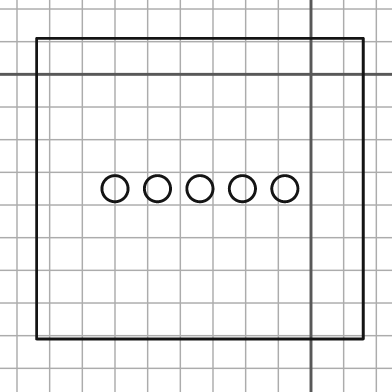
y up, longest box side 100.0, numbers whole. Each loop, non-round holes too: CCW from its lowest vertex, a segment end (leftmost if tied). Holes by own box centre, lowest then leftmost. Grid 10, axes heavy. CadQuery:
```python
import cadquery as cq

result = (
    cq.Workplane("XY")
    .moveTo(-84.0, -81.0)
    .lineTo(16.0, -81.0)
    .lineTo(16.0, 11.0)
    .lineTo(-84.0, 11.0)
    .close()
    .moveTo(-60.0, -35.0)
    .circle(4.0)
    .moveTo(-47.0, -35.0)
    .circle(4.0)
    .moveTo(-34.0, -35.0)
    .circle(4.0)
    .moveTo(-21.0, -35.0)
    .circle(4.0)
    .moveTo(-8.0, -35.0)
    .circle(4.0)
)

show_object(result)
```